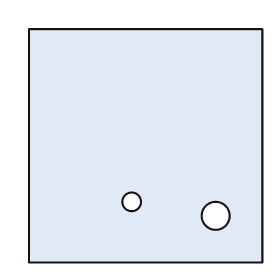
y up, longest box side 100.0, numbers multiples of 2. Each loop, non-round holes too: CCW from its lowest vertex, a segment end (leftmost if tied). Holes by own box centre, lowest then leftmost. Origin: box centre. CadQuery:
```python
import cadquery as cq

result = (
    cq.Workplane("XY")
    .moveTo(-50.0, -50.0)
    .lineTo(50.0, -50.0)
    .lineTo(50.0, 50.0)
    .lineTo(-50.0, 50.0)
    .close()
    .moveTo(30.0, -30.0)
    .circle(6.0)
    .moveTo(-6.0, -24.0)
    .circle(4.0)
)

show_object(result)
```